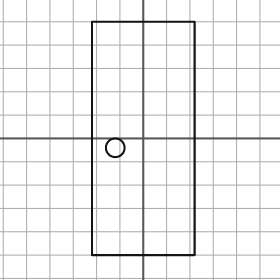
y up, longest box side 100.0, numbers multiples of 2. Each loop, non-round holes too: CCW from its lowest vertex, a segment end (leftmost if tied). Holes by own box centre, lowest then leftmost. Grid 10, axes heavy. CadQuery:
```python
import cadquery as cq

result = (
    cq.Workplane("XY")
    .moveTo(-22.0, -50.0)
    .lineTo(22.0, -50.0)
    .lineTo(22.0, 50.0)
    .lineTo(-22.0, 50.0)
    .close()
    .moveTo(-12.0, -4.0)
    .circle(4.0)
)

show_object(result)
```